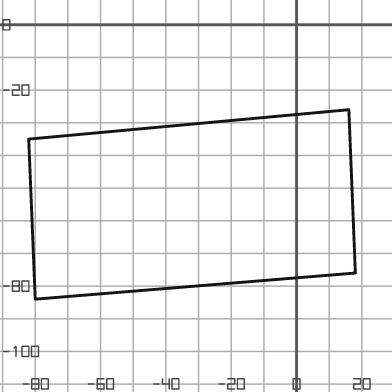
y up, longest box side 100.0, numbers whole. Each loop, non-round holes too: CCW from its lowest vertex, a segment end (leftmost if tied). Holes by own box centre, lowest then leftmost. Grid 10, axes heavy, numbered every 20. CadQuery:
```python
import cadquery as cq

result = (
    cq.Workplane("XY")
    .moveTo(-80.0, -84.0)
    .lineTo(18.0, -76.0)
    .lineTo(16.0, -26.0)
    .lineTo(-82.0, -35.0)
    .close()
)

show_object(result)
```